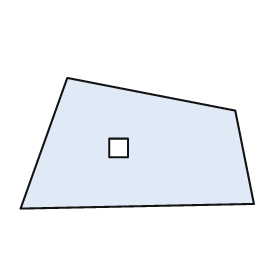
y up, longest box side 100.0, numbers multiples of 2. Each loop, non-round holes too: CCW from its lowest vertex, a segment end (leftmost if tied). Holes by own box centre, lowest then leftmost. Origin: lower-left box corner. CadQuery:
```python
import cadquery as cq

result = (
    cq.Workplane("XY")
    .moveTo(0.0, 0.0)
    .lineTo(100.0, 2.0)
    .lineTo(92.0, 42.0)
    .lineTo(20.0, 56.0)
    .close()
    .moveTo(38.0, 22.0)
    .lineTo(46.0, 22.0)
    .lineTo(46.0, 30.0)
    .lineTo(38.0, 30.0)
    .close()
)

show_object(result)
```